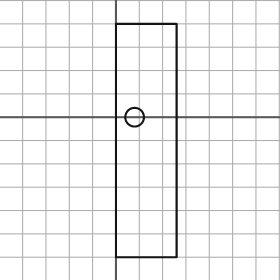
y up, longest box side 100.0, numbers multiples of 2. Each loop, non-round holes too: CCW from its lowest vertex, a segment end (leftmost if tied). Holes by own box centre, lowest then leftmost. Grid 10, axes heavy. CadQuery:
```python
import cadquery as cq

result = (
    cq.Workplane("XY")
    .moveTo(0.0, -60.0)
    .lineTo(26.0, -60.0)
    .lineTo(26.0, 40.0)
    .lineTo(0.0, 40.0)
    .close()
    .moveTo(8.0, 0.0)
    .circle(4.0)
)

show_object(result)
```